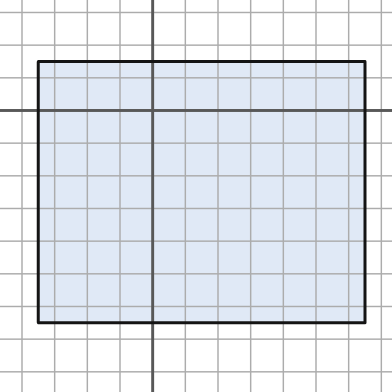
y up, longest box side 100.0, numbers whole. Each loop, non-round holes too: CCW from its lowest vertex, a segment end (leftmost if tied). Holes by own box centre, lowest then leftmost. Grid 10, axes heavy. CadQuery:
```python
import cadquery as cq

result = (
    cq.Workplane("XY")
    .moveTo(-35.0, -65.0)
    .lineTo(65.0, -65.0)
    .lineTo(65.0, 15.0)
    .lineTo(-35.0, 15.0)
    .close()
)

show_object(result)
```